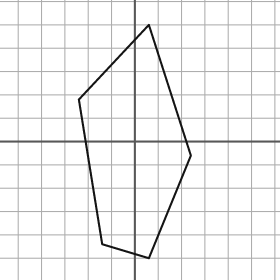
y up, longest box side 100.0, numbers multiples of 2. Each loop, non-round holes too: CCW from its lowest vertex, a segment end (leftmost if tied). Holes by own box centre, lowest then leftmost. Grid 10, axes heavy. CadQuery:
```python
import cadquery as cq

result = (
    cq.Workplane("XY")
    .moveTo(6.0, -50.0)
    .lineTo(24.0, -6.0)
    .lineTo(6.0, 50.0)
    .lineTo(-24.0, 18.0)
    .lineTo(-14.0, -44.0)
    .close()
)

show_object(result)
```